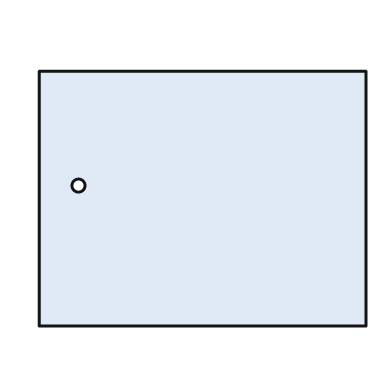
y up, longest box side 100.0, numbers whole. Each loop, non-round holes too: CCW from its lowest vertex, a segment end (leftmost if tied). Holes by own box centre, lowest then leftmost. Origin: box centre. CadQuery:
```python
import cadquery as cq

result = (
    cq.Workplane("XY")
    .moveTo(-50.0, -39.0)
    .lineTo(50.0, -39.0)
    .lineTo(50.0, 39.0)
    .lineTo(-50.0, 39.0)
    .close()
    .moveTo(-38.0, 4.0)
    .circle(2.0)
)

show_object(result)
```